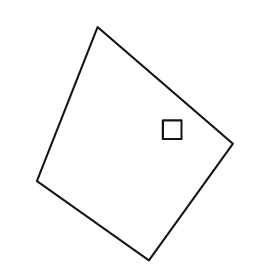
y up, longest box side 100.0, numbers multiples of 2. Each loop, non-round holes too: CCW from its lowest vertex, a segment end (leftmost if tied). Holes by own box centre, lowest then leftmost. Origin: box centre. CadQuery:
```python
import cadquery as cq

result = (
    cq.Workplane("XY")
    .moveTo(6.0, -50.0)
    .lineTo(42.0, 0.0)
    .lineTo(-16.0, 50.0)
    .lineTo(-42.0, -16.0)
    .close()
    .moveTo(12.0, 2.0)
    .lineTo(20.0, 2.0)
    .lineTo(20.0, 10.0)
    .lineTo(12.0, 10.0)
    .close()
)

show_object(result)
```